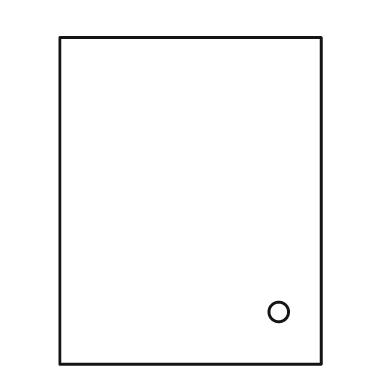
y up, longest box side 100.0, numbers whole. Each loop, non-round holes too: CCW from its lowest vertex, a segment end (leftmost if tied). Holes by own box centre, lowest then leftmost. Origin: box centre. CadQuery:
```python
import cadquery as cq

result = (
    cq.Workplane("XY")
    .moveTo(-40.0, -50.0)
    .lineTo(40.0, -50.0)
    .lineTo(40.0, 50.0)
    .lineTo(-40.0, 50.0)
    .close()
    .moveTo(27.0, -34.0)
    .circle(3.0)
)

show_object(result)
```